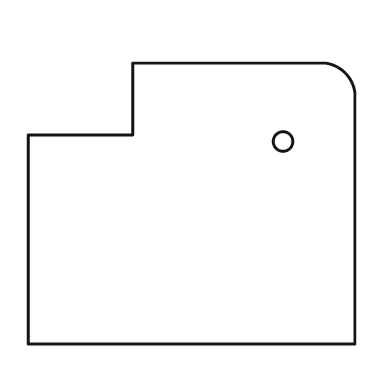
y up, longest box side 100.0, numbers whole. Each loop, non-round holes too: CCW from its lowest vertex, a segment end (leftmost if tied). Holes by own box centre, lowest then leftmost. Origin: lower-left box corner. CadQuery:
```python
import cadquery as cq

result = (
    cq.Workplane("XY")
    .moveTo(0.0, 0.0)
    .lineTo(100.0, 0.0)
    .lineTo(100.0, 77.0)
    .threePointArc((97.0, 83.0), (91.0, 86.0))
    .lineTo(32.0, 86.0)
    .lineTo(32.0, 64.0)
    .lineTo(0.0, 64.0)
    .close()
    .moveTo(78.0, 62.0)
    .circle(3.0)
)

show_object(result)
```